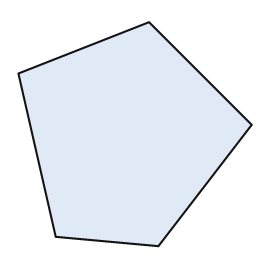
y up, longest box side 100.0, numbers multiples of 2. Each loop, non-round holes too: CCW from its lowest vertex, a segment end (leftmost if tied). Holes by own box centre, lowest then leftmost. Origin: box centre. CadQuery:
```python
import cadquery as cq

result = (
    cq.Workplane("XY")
    .moveTo(10.0, -48.0)
    .lineTo(50.0, 4.0)
    .lineTo(6.0, 48.0)
    .lineTo(-50.0, 26.0)
    .lineTo(-34.0, -44.0)
    .close()
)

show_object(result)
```